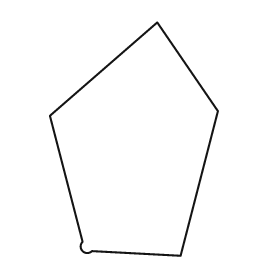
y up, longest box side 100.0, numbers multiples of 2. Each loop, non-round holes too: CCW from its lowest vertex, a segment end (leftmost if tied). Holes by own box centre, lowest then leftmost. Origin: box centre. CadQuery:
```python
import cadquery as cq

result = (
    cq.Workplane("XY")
    .moveTo(20.0, -50.0)
    .lineTo(36.0, 12.0)
    .lineTo(10.0, 50.0)
    .lineTo(-36.0, 10.0)
    .lineTo(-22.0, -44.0)
    .threePointArc((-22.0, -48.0), (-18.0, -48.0))
    .close()
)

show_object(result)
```